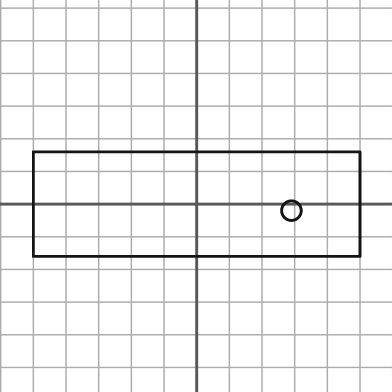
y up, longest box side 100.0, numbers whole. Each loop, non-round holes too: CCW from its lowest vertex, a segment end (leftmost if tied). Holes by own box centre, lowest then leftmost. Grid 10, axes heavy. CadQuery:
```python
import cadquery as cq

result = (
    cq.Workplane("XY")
    .moveTo(-50.0, -16.0)
    .lineTo(50.0, -16.0)
    .lineTo(50.0, 16.0)
    .lineTo(-50.0, 16.0)
    .close()
    .moveTo(29.0, -2.0)
    .circle(3.0)
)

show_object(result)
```